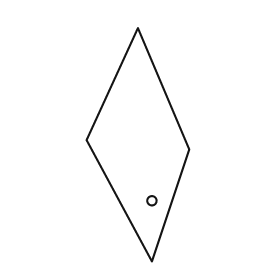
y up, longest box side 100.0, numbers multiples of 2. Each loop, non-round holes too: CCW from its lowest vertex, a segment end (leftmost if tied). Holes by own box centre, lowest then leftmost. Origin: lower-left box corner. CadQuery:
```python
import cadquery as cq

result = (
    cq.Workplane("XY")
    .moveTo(28.0, 0.0)
    .lineTo(44.0, 48.0)
    .lineTo(22.0, 100.0)
    .lineTo(0.0, 52.0)
    .close()
    .moveTo(28.0, 26.0)
    .circle(2.0)
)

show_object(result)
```